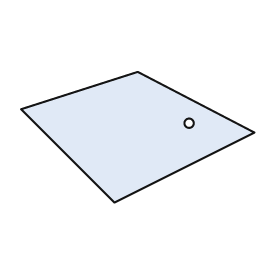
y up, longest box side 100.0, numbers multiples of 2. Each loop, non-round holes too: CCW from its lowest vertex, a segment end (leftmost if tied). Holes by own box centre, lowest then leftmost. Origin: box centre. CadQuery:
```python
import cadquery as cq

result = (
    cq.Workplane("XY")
    .moveTo(-10.0, -28.0)
    .lineTo(50.0, 2.0)
    .lineTo(0.0, 28.0)
    .lineTo(-50.0, 12.0)
    .close()
    .moveTo(22.0, 6.0)
    .circle(2.0)
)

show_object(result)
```